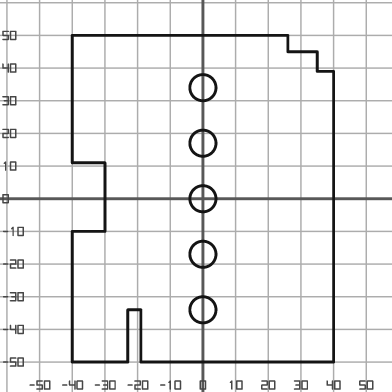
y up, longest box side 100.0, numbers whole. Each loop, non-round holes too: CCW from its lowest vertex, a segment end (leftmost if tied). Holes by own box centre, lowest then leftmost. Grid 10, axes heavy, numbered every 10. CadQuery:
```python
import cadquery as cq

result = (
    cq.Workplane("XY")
    .moveTo(-40.0, -50.0)
    .lineTo(-23.0, -50.0)
    .lineTo(-23.0, -34.0)
    .lineTo(-19.0, -34.0)
    .lineTo(-19.0, -50.0)
    .lineTo(40.0, -50.0)
    .lineTo(40.0, 39.0)
    .lineTo(35.0, 39.0)
    .lineTo(35.0, 45.0)
    .lineTo(26.0, 45.0)
    .lineTo(26.0, 50.0)
    .lineTo(-40.0, 50.0)
    .lineTo(-40.0, 11.0)
    .lineTo(-30.0, 11.0)
    .lineTo(-30.0, -10.0)
    .lineTo(-40.0, -10.0)
    .close()
    .moveTo(0.0, -34.0)
    .circle(4.0)
    .moveTo(0.0, -17.0)
    .circle(4.0)
    .moveTo(0.0, 0.0)
    .circle(4.0)
    .moveTo(0.0, 17.0)
    .circle(4.0)
    .moveTo(0.0, 34.0)
    .circle(4.0)
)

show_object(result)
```